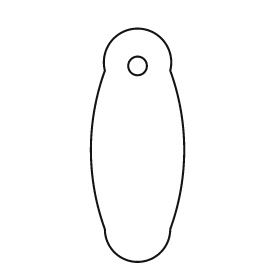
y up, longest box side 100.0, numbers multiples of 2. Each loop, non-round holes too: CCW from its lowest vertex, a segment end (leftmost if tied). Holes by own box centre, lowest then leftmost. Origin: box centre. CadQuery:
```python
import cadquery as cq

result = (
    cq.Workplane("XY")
    .moveTo(-14.0, -36.0)
    .threePointArc((0.0, -50.0), (14.0, -36.0))
    .threePointArc((20.0, -2.0), (14.0, 32.0))
    .threePointArc((0.0, 50.0), (-14.0, 32.0))
    .threePointArc((-20.0, -2.0), (-14.0, -36.0))
    .close()
    .moveTo(0.0, 34.0)
    .circle(4.0)
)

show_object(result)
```